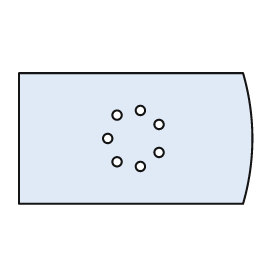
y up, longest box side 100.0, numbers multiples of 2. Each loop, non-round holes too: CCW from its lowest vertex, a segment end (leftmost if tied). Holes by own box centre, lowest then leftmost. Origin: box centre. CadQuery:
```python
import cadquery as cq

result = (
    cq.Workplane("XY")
    .moveTo(-50.0, -28.0)
    .lineTo(46.0, -28.0)
    .threePointArc((50.0, 0.0), (46.0, 28.0))
    .lineTo(-50.0, 28.0)
    .close()
    .moveTo(2.0, -12.0)
    .circle(2.0)
    .moveTo(-8.0, -10.0)
    .circle(2.0)
    .moveTo(10.0, -6.0)
    .circle(2.0)
    .moveTo(-12.0, 0.0)
    .circle(2.0)
    .moveTo(10.0, 6.0)
    .circle(2.0)
    .moveTo(-8.0, 10.0)
    .circle(2.0)
    .moveTo(2.0, 12.0)
    .circle(2.0)
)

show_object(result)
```